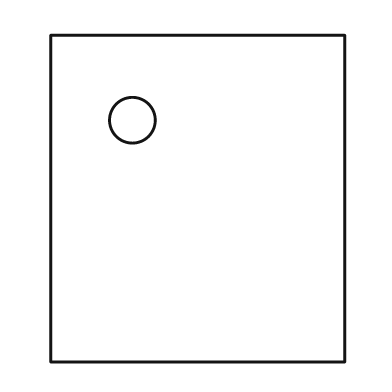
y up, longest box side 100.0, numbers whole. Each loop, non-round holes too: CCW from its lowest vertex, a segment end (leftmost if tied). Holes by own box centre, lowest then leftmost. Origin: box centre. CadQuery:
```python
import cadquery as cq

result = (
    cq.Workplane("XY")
    .moveTo(-45.0, -50.0)
    .lineTo(45.0, -50.0)
    .lineTo(45.0, 50.0)
    .lineTo(-45.0, 50.0)
    .close()
    .moveTo(-20.0, 24.0)
    .circle(7.0)
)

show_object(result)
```